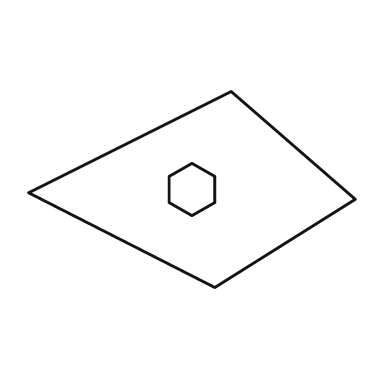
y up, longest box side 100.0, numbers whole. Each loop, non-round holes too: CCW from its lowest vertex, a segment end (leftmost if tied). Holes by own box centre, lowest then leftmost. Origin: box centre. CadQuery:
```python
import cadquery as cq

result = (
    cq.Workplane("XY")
    .moveTo(7.0, -30.0)
    .lineTo(50.0, -3.0)
    .lineTo(12.0, 30.0)
    .lineTo(-50.0, -1.0)
    .close()
    .moveTo(0.0, -8.0)
    .lineTo(7.0, -4.0)
    .lineTo(7.0, 4.0)
    .lineTo(0.0, 8.0)
    .lineTo(-7.0, 4.0)
    .lineTo(-7.0, -4.0)
    .close()
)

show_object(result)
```